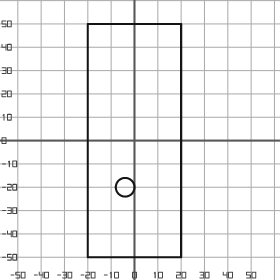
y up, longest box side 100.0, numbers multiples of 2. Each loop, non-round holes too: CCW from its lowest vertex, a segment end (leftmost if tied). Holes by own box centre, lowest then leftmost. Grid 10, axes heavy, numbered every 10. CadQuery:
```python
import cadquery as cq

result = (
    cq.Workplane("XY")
    .moveTo(-20.0, -50.0)
    .lineTo(20.0, -50.0)
    .lineTo(20.0, 50.0)
    .lineTo(-20.0, 50.0)
    .close()
    .moveTo(-4.0, -20.0)
    .circle(4.0)
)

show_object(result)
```